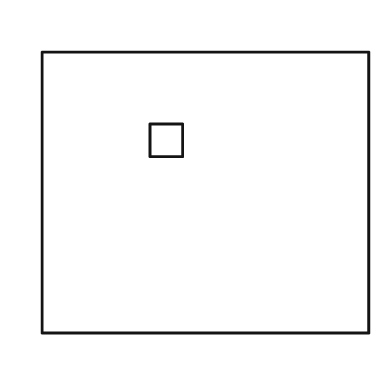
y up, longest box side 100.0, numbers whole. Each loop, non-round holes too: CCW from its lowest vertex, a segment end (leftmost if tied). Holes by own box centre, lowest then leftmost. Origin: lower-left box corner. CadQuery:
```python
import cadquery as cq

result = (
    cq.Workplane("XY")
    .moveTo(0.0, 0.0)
    .lineTo(100.0, 0.0)
    .lineTo(100.0, 86.0)
    .lineTo(0.0, 86.0)
    .close()
    .moveTo(33.0, 54.0)
    .lineTo(43.0, 54.0)
    .lineTo(43.0, 64.0)
    .lineTo(33.0, 64.0)
    .close()
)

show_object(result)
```